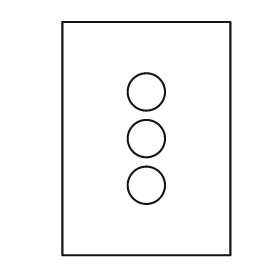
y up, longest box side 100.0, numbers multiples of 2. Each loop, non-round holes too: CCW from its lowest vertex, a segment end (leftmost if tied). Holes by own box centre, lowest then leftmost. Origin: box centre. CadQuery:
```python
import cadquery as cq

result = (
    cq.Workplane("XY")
    .moveTo(-36.0, -50.0)
    .lineTo(36.0, -50.0)
    .lineTo(36.0, 50.0)
    .lineTo(-36.0, 50.0)
    .close()
    .moveTo(0.0, -20.0)
    .circle(8.0)
    .moveTo(0.0, 0.0)
    .circle(8.0)
    .moveTo(0.0, 20.0)
    .circle(8.0)
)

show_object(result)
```